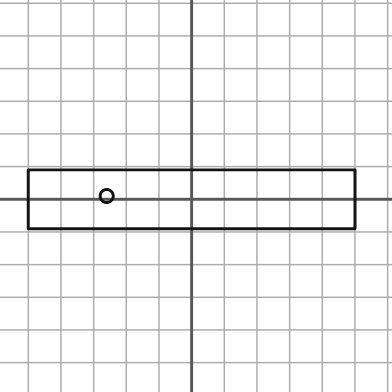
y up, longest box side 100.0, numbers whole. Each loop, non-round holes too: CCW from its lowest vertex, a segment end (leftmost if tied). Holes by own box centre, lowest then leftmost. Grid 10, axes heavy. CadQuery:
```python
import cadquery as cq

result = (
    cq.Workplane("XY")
    .moveTo(-50.0, -9.0)
    .lineTo(50.0, -9.0)
    .lineTo(50.0, 9.0)
    .lineTo(-50.0, 9.0)
    .close()
    .moveTo(-26.0, 1.0)
    .circle(2.0)
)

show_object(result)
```